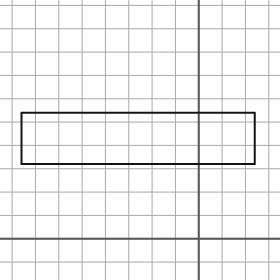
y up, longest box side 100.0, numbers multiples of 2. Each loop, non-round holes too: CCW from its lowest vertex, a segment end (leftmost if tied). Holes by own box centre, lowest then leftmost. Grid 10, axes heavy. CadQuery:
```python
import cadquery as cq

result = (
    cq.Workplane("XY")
    .moveTo(-76.0, 32.0)
    .lineTo(24.0, 32.0)
    .lineTo(24.0, 54.0)
    .lineTo(-76.0, 54.0)
    .close()
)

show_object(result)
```